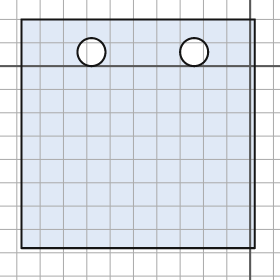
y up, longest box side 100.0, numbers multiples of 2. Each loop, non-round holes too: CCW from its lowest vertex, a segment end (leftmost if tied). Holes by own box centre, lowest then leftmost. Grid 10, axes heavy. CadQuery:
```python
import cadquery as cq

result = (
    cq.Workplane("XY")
    .moveTo(-98.0, -78.0)
    .lineTo(2.0, -78.0)
    .lineTo(2.0, 20.0)
    .lineTo(-98.0, 20.0)
    .close()
    .moveTo(-68.0, 6.0)
    .circle(6.0)
    .moveTo(-24.0, 6.0)
    .circle(6.0)
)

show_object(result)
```